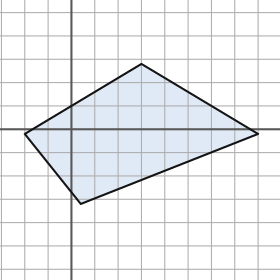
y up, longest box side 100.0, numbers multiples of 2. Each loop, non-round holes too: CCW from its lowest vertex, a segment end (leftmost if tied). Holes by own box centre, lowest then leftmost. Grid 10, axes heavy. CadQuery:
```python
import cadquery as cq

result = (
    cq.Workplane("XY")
    .moveTo(4.0, -32.0)
    .lineTo(80.0, -2.0)
    .lineTo(30.0, 28.0)
    .lineTo(-20.0, -2.0)
    .close()
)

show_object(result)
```